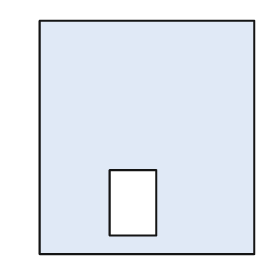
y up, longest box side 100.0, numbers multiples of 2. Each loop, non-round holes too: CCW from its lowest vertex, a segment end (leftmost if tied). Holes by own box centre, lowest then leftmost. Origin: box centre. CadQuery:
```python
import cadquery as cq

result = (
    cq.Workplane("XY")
    .moveTo(-46.0, -50.0)
    .lineTo(46.0, -50.0)
    .lineTo(46.0, 50.0)
    .lineTo(-46.0, 50.0)
    .close()
    .moveTo(-16.0, -42.0)
    .lineTo(4.0, -42.0)
    .lineTo(4.0, -14.0)
    .lineTo(-16.0, -14.0)
    .close()
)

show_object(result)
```